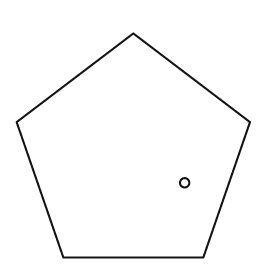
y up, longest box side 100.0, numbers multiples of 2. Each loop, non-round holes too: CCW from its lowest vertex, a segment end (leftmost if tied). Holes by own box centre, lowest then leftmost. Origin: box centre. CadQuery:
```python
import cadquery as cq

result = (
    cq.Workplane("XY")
    .moveTo(-30.0, -48.0)
    .lineTo(30.0, -48.0)
    .lineTo(50.0, 10.0)
    .lineTo(0.0, 48.0)
    .lineTo(-50.0, 10.0)
    .close()
    .moveTo(22.0, -16.0)
    .circle(2.0)
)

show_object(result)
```